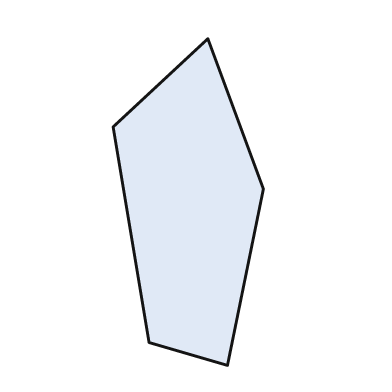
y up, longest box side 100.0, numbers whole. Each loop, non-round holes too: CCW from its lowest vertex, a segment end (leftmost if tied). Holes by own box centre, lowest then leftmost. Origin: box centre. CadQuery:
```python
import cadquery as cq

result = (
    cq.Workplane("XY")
    .moveTo(12.0, -50.0)
    .lineTo(23.0, 4.0)
    .lineTo(6.0, 50.0)
    .lineTo(-23.0, 23.0)
    .lineTo(-12.0, -43.0)
    .close()
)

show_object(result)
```